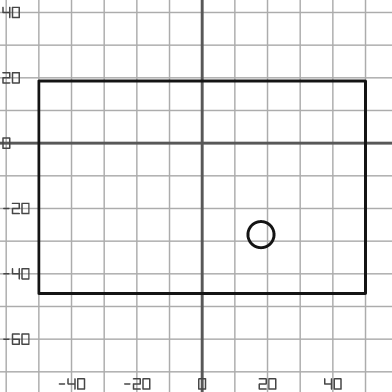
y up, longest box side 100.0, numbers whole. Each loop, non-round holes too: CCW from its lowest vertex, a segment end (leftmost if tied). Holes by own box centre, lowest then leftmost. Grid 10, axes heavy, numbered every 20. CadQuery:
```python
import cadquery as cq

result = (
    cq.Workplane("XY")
    .moveTo(-50.0, -46.0)
    .lineTo(50.0, -46.0)
    .lineTo(50.0, 19.0)
    .lineTo(-50.0, 19.0)
    .close()
    .moveTo(18.0, -28.0)
    .circle(4.0)
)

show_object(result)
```